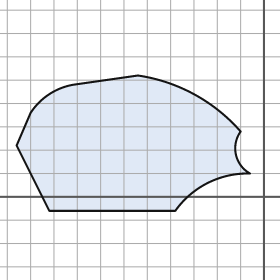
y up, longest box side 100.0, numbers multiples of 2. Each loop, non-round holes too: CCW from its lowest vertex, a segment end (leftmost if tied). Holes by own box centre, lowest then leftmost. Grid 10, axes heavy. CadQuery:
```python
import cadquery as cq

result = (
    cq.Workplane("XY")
    .moveTo(-92.0, -6.0)
    .lineTo(-38.0, -6.0)
    .threePointArc((-24.0, 6.0), (-6.0, 10.0))
    .threePointArc((-12.0, 18.0), (-10.0, 28.0))
    .threePointArc((-30.0, 44.0), (-54.0, 52.0))
    .lineTo(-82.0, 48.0)
    .threePointArc((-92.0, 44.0), (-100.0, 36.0))
    .lineTo(-106.0, 22.0)
    .close()
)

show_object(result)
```